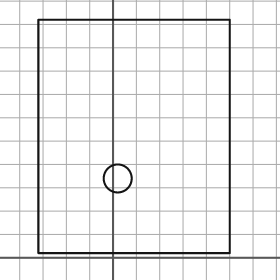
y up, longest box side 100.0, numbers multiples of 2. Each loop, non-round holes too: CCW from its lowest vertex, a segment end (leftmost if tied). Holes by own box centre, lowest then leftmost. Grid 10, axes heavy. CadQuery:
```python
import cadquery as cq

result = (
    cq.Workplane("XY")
    .moveTo(-32.0, 2.0)
    .lineTo(50.0, 2.0)
    .lineTo(50.0, 102.0)
    .lineTo(-32.0, 102.0)
    .close()
    .moveTo(2.0, 34.0)
    .circle(6.0)
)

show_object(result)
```